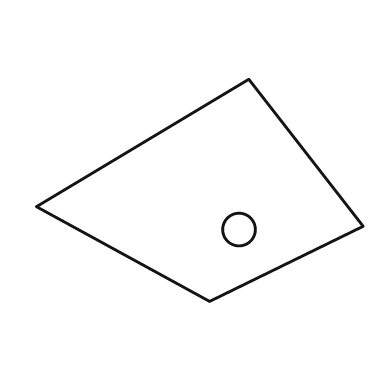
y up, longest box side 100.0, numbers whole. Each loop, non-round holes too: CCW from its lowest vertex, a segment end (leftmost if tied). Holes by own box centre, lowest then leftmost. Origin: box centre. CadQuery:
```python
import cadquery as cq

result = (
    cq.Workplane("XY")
    .moveTo(3.0, -34.0)
    .lineTo(50.0, -11.0)
    .lineTo(15.0, 34.0)
    .lineTo(-50.0, -5.0)
    .close()
    .moveTo(12.0, -12.0)
    .circle(5.0)
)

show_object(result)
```